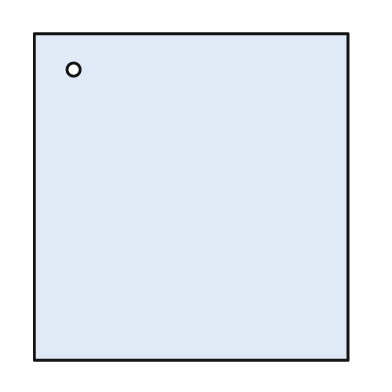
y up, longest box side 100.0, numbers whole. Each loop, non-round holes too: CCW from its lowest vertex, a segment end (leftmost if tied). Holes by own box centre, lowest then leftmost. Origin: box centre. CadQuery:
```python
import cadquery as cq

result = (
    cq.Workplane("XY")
    .moveTo(-48.0, -50.0)
    .lineTo(48.0, -50.0)
    .lineTo(48.0, 50.0)
    .lineTo(-48.0, 50.0)
    .close()
    .moveTo(-36.0, 39.0)
    .circle(2.0)
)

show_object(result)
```